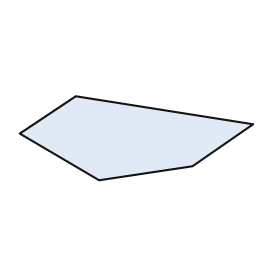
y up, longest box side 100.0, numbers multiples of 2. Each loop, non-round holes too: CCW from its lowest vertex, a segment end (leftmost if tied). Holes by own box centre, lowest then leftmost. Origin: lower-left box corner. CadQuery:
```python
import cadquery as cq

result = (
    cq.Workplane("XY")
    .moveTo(34.0, 0.0)
    .lineTo(74.0, 6.0)
    .lineTo(100.0, 24.0)
    .lineTo(24.0, 36.0)
    .lineTo(0.0, 20.0)
    .close()
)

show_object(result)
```